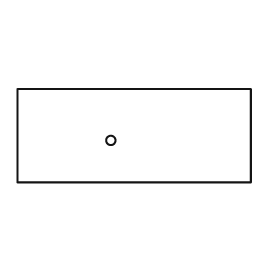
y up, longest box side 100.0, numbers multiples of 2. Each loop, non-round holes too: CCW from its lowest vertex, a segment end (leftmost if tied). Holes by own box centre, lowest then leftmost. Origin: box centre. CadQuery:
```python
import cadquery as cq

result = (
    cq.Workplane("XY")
    .moveTo(-50.0, -20.0)
    .lineTo(50.0, -20.0)
    .lineTo(50.0, 20.0)
    .lineTo(-50.0, 20.0)
    .close()
    .moveTo(-10.0, -2.0)
    .circle(2.0)
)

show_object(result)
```